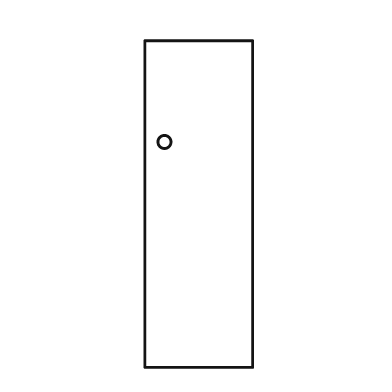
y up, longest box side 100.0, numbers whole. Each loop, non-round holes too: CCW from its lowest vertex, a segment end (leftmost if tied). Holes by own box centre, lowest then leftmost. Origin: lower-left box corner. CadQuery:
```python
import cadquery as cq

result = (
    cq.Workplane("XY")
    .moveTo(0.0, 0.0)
    .lineTo(33.0, 0.0)
    .lineTo(33.0, 100.0)
    .lineTo(0.0, 100.0)
    .close()
    .moveTo(6.0, 69.0)
    .circle(2.0)
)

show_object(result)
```